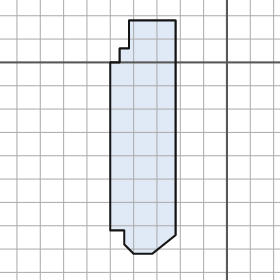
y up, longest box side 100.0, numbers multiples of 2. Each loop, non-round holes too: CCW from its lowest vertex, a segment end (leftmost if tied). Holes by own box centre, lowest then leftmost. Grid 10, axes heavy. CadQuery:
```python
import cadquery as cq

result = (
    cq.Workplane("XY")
    .moveTo(-40.0, -82.0)
    .lineTo(-32.0, -82.0)
    .lineTo(-22.0, -74.0)
    .lineTo(-22.0, 18.0)
    .lineTo(-42.0, 18.0)
    .lineTo(-42.0, 6.0)
    .lineTo(-46.0, 6.0)
    .lineTo(-46.0, 0.0)
    .lineTo(-50.0, 0.0)
    .lineTo(-50.0, -72.0)
    .lineTo(-44.0, -72.0)
    .lineTo(-44.0, -78.0)
    .close()
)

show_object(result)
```